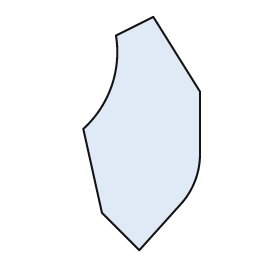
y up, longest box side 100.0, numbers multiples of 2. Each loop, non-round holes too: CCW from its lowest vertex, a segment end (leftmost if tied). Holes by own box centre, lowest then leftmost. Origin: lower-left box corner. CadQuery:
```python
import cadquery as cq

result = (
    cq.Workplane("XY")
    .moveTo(24.0, 0.0)
    .lineTo(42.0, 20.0)
    .threePointArc((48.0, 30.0), (50.0, 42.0))
    .lineTo(50.0, 68.0)
    .lineTo(30.0, 100.0)
    .lineTo(14.0, 92.0)
    .threePointArc((12.0, 70.0), (0.0, 52.0))
    .lineTo(8.0, 16.0)
    .close()
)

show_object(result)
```